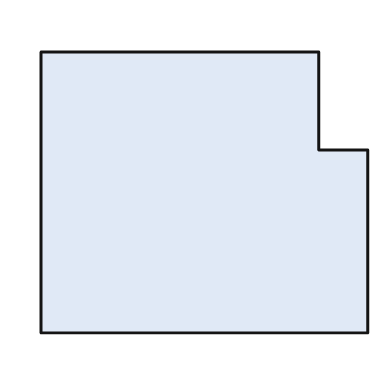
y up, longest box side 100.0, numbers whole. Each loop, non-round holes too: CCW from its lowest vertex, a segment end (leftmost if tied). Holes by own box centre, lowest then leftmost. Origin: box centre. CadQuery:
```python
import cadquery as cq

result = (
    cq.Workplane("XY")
    .moveTo(-50.0, -43.0)
    .lineTo(50.0, -43.0)
    .lineTo(50.0, 13.0)
    .lineTo(35.0, 13.0)
    .lineTo(35.0, 43.0)
    .lineTo(-50.0, 43.0)
    .close()
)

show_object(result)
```